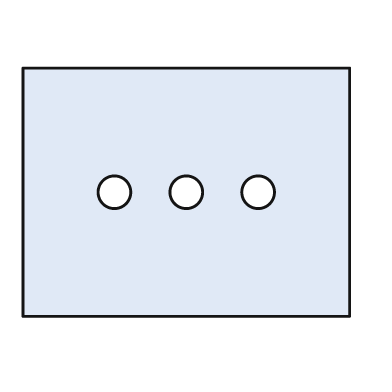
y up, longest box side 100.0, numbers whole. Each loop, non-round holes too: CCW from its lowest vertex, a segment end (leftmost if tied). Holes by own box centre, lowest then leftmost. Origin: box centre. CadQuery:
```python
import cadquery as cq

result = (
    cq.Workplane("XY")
    .moveTo(-50.0, -38.0)
    .lineTo(50.0, -38.0)
    .lineTo(50.0, 38.0)
    .lineTo(-50.0, 38.0)
    .close()
    .moveTo(-22.0, 0.0)
    .circle(5.0)
    .moveTo(0.0, 0.0)
    .circle(5.0)
    .moveTo(22.0, 0.0)
    .circle(5.0)
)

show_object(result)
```